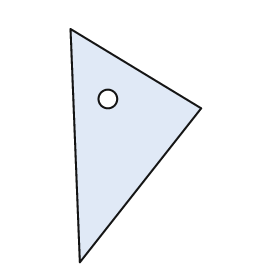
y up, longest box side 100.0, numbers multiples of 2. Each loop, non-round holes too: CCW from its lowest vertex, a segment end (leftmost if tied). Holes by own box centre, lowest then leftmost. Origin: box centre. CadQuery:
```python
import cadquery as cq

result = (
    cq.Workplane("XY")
    .moveTo(-24.0, -50.0)
    .lineTo(28.0, 16.0)
    .lineTo(-28.0, 50.0)
    .close()
    .moveTo(-12.0, 20.0)
    .circle(4.0)
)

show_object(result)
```